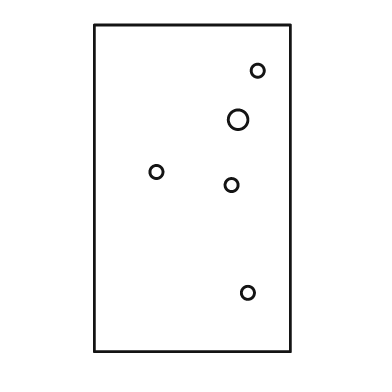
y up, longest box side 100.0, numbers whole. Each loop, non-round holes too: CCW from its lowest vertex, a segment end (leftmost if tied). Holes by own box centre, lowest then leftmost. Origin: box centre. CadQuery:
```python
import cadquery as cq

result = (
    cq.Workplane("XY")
    .moveTo(-30.0, -50.0)
    .lineTo(30.0, -50.0)
    .lineTo(30.0, 50.0)
    .lineTo(-30.0, 50.0)
    .close()
    .moveTo(17.0, -32.0)
    .circle(2.0)
    .moveTo(12.0, 1.0)
    .circle(2.0)
    .moveTo(-11.0, 5.0)
    .circle(2.0)
    .moveTo(14.0, 21.0)
    .circle(3.0)
    .moveTo(20.0, 36.0)
    .circle(2.0)
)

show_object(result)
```